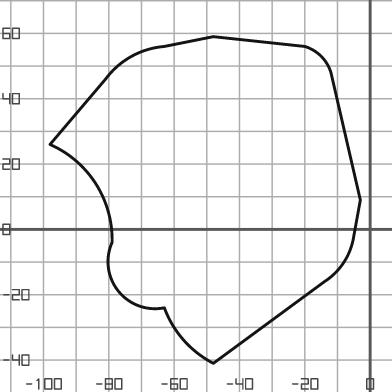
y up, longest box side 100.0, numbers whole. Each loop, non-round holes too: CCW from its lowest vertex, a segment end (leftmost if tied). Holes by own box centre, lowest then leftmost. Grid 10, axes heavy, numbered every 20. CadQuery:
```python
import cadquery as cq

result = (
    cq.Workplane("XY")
    .moveTo(-48.0, -41.0)
    .lineTo(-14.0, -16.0)
    .threePointArc((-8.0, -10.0), (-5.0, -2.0))
    .lineTo(-3.0, 9.0)
    .lineTo(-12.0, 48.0)
    .threePointArc((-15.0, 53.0), (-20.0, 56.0))
    .lineTo(-48.0, 59.0)
    .lineTo(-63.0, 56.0)
    .threePointArc((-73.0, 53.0), (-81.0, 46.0))
    .lineTo(-98.0, 26.0)
    .threePointArc((-84.0, 14.0), (-79.0, -4.0))
    .threePointArc((-77.0, -19.0), (-63.0, -24.0))
    .threePointArc((-57.0, -34.0), (-48.0, -41.0))
    .close()
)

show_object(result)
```